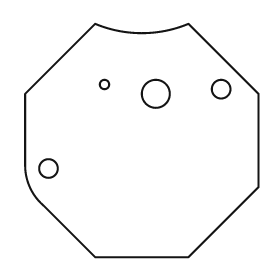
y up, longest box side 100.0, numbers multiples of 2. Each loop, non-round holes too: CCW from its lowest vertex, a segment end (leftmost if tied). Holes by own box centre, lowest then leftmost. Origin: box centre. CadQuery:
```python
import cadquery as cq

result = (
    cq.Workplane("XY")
    .moveTo(-20.0, -50.0)
    .lineTo(20.0, -50.0)
    .lineTo(50.0, -20.0)
    .lineTo(50.0, 20.0)
    .lineTo(20.0, 50.0)
    .threePointArc((0.0, 46.0), (-20.0, 50.0))
    .lineTo(-50.0, 20.0)
    .lineTo(-50.0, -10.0)
    .threePointArc((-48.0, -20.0), (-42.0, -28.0))
    .close()
    .moveTo(-40.0, -12.0)
    .circle(4.0)
    .moveTo(6.0, 20.0)
    .circle(6.0)
    .moveTo(34.0, 22.0)
    .circle(4.0)
    .moveTo(-16.0, 24.0)
    .circle(2.0)
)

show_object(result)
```